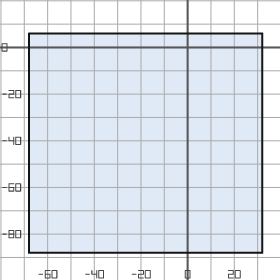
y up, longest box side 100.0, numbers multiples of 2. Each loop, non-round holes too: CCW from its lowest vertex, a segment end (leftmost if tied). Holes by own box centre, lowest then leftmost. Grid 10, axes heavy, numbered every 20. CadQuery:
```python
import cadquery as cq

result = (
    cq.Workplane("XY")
    .moveTo(-68.0, -88.0)
    .lineTo(32.0, -88.0)
    .lineTo(32.0, 6.0)
    .lineTo(-68.0, 6.0)
    .close()
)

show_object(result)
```